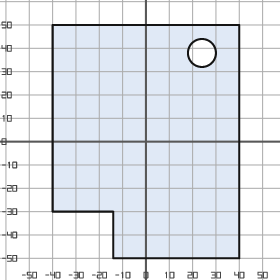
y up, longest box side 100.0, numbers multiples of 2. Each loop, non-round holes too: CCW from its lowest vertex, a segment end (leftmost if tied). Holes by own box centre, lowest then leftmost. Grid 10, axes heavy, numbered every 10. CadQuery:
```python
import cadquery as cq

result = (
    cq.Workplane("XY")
    .moveTo(-14.0, -50.0)
    .lineTo(40.0, -50.0)
    .lineTo(40.0, 50.0)
    .lineTo(-40.0, 50.0)
    .lineTo(-40.0, -30.0)
    .lineTo(-14.0, -30.0)
    .close()
    .moveTo(24.0, 38.0)
    .circle(6.0)
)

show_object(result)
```